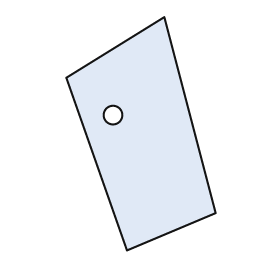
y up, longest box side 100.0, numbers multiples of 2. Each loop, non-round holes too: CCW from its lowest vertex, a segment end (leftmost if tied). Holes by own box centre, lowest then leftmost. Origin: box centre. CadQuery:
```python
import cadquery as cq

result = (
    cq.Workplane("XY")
    .moveTo(-6.0, -50.0)
    .lineTo(32.0, -34.0)
    .lineTo(10.0, 50.0)
    .lineTo(-32.0, 24.0)
    .close()
    .moveTo(-12.0, 8.0)
    .circle(4.0)
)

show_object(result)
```